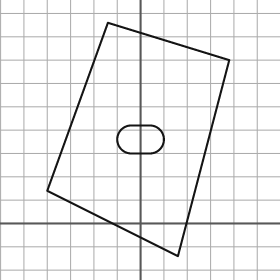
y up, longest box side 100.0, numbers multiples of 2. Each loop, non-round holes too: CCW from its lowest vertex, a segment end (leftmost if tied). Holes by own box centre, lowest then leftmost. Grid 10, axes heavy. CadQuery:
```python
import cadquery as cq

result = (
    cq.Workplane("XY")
    .moveTo(16.0, -14.0)
    .lineTo(38.0, 70.0)
    .lineTo(-14.0, 86.0)
    .lineTo(-40.0, 14.0)
    .close()
    .moveTo(-4.0, 30.0)
    .lineTo(4.0, 30.0)
    .threePointArc((10.0, 36.0), (4.0, 42.0))
    .lineTo(-4.0, 42.0)
    .threePointArc((-10.0, 36.0), (-4.0, 30.0))
    .close()
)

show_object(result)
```